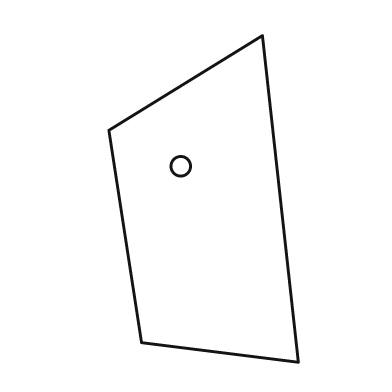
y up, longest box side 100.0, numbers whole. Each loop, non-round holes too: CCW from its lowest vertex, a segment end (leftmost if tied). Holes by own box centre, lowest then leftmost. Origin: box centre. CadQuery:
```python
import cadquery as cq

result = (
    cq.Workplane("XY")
    .moveTo(29.0, -50.0)
    .lineTo(18.0, 50.0)
    .lineTo(-29.0, 21.0)
    .lineTo(-19.0, -44.0)
    .close()
    .moveTo(-7.0, 10.0)
    .circle(3.0)
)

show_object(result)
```